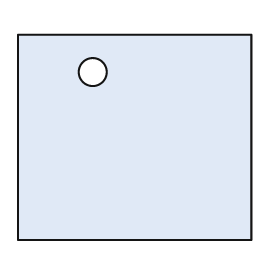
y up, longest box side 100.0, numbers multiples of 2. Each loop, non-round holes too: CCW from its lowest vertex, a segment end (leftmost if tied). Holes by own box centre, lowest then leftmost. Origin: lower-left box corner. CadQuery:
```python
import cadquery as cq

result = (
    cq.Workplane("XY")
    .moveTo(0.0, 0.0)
    .lineTo(100.0, 0.0)
    .lineTo(100.0, 88.0)
    .lineTo(0.0, 88.0)
    .close()
    .moveTo(32.0, 72.0)
    .circle(6.0)
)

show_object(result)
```